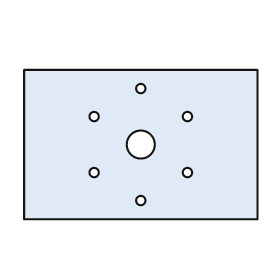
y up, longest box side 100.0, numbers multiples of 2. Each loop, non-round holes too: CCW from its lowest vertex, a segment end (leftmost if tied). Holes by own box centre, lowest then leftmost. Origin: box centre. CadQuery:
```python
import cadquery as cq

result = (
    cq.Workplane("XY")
    .moveTo(-50.0, -32.0)
    .lineTo(50.0, -32.0)
    .lineTo(50.0, 32.0)
    .lineTo(-50.0, 32.0)
    .close()
    .moveTo(0.0, -24.0)
    .circle(2.0)
    .moveTo(-20.0, -12.0)
    .circle(2.0)
    .moveTo(20.0, -12.0)
    .circle(2.0)
    .moveTo(0.0, 0.0)
    .circle(6.0)
    .moveTo(-20.0, 12.0)
    .circle(2.0)
    .moveTo(20.0, 12.0)
    .circle(2.0)
    .moveTo(0.0, 24.0)
    .circle(2.0)
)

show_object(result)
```